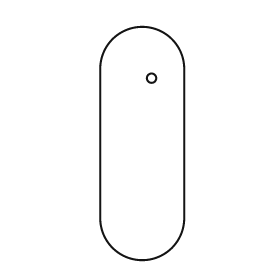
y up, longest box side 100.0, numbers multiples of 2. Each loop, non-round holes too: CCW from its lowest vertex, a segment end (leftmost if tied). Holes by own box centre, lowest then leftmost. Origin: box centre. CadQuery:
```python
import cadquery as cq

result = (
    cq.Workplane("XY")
    .moveTo(-18.0, -32.0)
    .threePointArc((0.0, -50.0), (18.0, -32.0))
    .lineTo(18.0, 32.0)
    .threePointArc((0.0, 50.0), (-18.0, 32.0))
    .close()
    .moveTo(4.0, 28.0)
    .circle(2.0)
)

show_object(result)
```